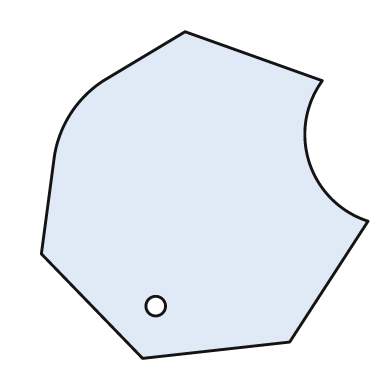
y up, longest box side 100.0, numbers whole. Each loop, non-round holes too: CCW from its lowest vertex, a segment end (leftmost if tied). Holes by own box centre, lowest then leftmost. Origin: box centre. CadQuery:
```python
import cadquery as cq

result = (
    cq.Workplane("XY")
    .moveTo(-19.0, -50.0)
    .lineTo(26.0, -45.0)
    .lineTo(50.0, -8.0)
    .threePointArc((32.0, 10.0), (36.0, 35.0))
    .lineTo(-6.0, 50.0)
    .lineTo(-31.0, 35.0)
    .threePointArc((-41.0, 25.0), (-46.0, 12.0))
    .lineTo(-50.0, -18.0)
    .close()
    .moveTo(-15.0, -34.0)
    .circle(3.0)
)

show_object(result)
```